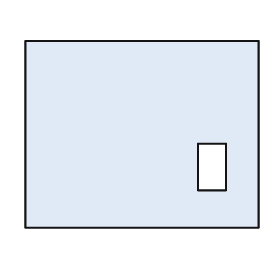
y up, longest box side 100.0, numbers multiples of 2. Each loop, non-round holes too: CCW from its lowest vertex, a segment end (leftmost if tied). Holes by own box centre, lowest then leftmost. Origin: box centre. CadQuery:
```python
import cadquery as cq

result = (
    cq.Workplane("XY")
    .moveTo(-50.0, -40.0)
    .lineTo(50.0, -40.0)
    .lineTo(50.0, 40.0)
    .lineTo(-50.0, 40.0)
    .close()
    .moveTo(24.0, -24.0)
    .lineTo(36.0, -24.0)
    .lineTo(36.0, -4.0)
    .lineTo(24.0, -4.0)
    .close()
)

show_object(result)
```